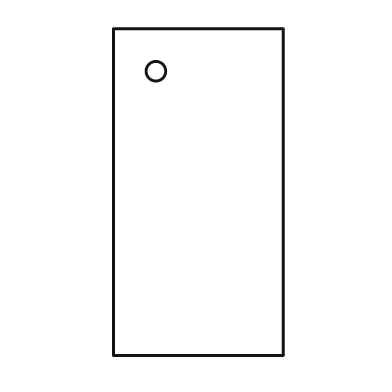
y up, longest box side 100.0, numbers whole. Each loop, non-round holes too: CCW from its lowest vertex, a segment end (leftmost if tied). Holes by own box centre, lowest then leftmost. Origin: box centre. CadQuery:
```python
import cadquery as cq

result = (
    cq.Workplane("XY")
    .moveTo(-26.0, -50.0)
    .lineTo(26.0, -50.0)
    .lineTo(26.0, 50.0)
    .lineTo(-26.0, 50.0)
    .close()
    .moveTo(-13.0, 37.0)
    .circle(3.0)
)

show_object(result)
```